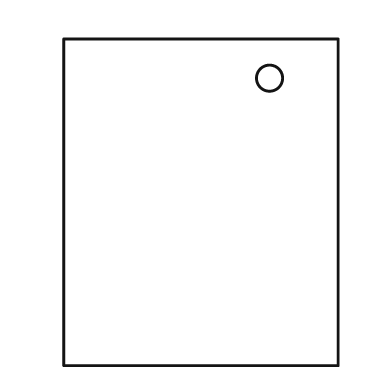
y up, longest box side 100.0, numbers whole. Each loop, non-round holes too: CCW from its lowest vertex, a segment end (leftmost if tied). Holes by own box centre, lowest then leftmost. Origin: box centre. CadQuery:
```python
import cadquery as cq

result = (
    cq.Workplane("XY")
    .moveTo(-42.0, -50.0)
    .lineTo(42.0, -50.0)
    .lineTo(42.0, 50.0)
    .lineTo(-42.0, 50.0)
    .close()
    .moveTo(21.0, 38.0)
    .circle(4.0)
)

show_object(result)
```